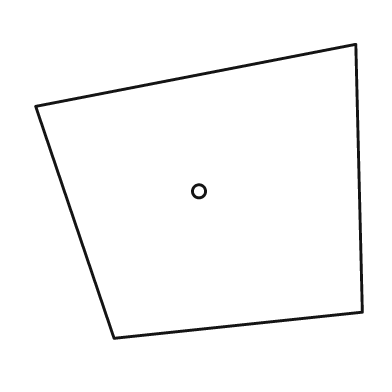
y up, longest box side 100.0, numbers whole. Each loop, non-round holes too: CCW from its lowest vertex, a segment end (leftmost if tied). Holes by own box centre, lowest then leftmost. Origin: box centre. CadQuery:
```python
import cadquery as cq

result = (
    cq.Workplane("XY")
    .moveTo(-26.0, -45.0)
    .lineTo(50.0, -37.0)
    .lineTo(48.0, 45.0)
    .lineTo(-50.0, 26.0)
    .close()
    .moveTo(0.0, 0.0)
    .circle(2.0)
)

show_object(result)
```